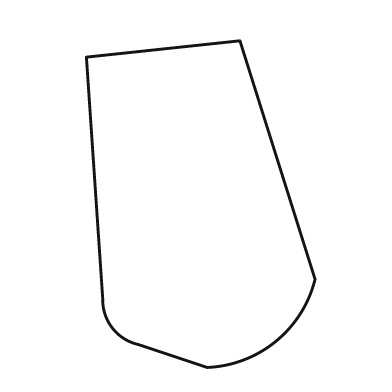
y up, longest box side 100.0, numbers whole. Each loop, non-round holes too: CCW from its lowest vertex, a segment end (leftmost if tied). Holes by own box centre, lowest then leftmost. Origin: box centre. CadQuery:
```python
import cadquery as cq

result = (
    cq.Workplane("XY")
    .moveTo(2.0, -50.0)
    .threePointArc((23.0, -42.0), (35.0, -23.0))
    .lineTo(12.0, 50.0)
    .lineTo(-35.0, 45.0)
    .lineTo(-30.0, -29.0)
    .threePointArc((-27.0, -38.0), (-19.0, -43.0))
    .close()
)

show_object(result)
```